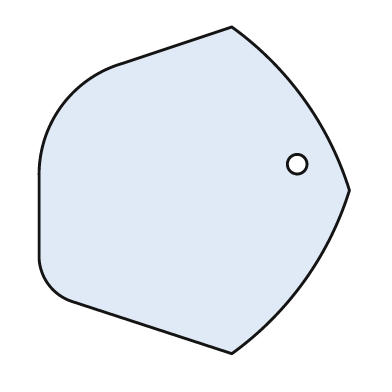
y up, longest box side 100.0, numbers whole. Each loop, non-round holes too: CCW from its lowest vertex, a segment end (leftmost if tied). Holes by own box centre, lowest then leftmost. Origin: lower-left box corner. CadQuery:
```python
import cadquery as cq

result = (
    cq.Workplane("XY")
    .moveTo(59.0, 0.0)
    .threePointArc((81.0, 22.0), (95.0, 50.0))
    .threePointArc((81.0, 78.0), (59.0, 100.0))
    .lineTo(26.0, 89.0)
    .threePointArc((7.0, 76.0), (0.0, 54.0))
    .lineTo(0.0, 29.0)
    .threePointArc((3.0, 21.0), (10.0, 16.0))
    .close()
    .moveTo(79.0, 58.0)
    .circle(3.0)
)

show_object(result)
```